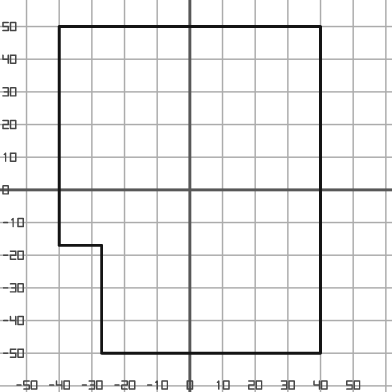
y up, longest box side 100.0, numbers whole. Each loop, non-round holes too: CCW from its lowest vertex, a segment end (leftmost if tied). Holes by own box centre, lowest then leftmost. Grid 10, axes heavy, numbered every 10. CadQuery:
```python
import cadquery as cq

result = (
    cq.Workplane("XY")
    .moveTo(-27.0, -50.0)
    .lineTo(40.0, -50.0)
    .lineTo(40.0, 50.0)
    .lineTo(-40.0, 50.0)
    .lineTo(-40.0, -17.0)
    .lineTo(-27.0, -17.0)
    .close()
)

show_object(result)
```